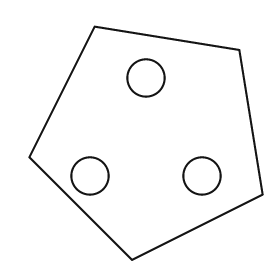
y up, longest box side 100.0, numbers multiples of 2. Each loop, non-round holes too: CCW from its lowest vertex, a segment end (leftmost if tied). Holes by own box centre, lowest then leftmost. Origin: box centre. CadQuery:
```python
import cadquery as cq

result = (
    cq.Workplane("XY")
    .moveTo(-6.0, -50.0)
    .lineTo(50.0, -22.0)
    .lineTo(40.0, 40.0)
    .lineTo(-22.0, 50.0)
    .lineTo(-50.0, -6.0)
    .close()
    .moveTo(-24.0, -14.0)
    .circle(8.0)
    .moveTo(24.0, -14.0)
    .circle(8.0)
    .moveTo(0.0, 28.0)
    .circle(8.0)
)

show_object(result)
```